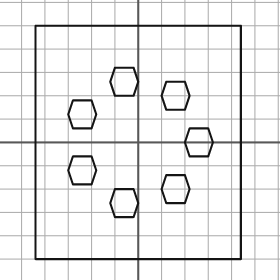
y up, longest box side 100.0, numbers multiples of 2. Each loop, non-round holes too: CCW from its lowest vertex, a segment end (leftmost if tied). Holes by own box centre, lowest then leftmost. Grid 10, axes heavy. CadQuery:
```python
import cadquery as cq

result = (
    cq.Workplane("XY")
    .moveTo(-44.0, -50.0)
    .lineTo(44.0, -50.0)
    .lineTo(44.0, 50.0)
    .lineTo(-44.0, 50.0)
    .close()
    .moveTo(-10.0, -32.0)
    .lineTo(-2.0, -32.0)
    .lineTo(0.0, -26.0)
    .lineTo(-2.0, -20.0)
    .lineTo(-10.0, -20.0)
    .lineTo(-12.0, -26.0)
    .close()
    .moveTo(12.0, -26.0)
    .lineTo(20.0, -26.0)
    .lineTo(22.0, -20.0)
    .lineTo(20.0, -14.0)
    .lineTo(12.0, -14.0)
    .lineTo(10.0, -20.0)
    .close()
    .moveTo(-28.0, -18.0)
    .lineTo(-20.0, -18.0)
    .lineTo(-18.0, -12.0)
    .lineTo(-20.0, -6.0)
    .lineTo(-28.0, -6.0)
    .lineTo(-30.0, -12.0)
    .close()
    .moveTo(22.0, -6.0)
    .lineTo(30.0, -6.0)
    .lineTo(32.0, 0.0)
    .lineTo(30.0, 6.0)
    .lineTo(22.0, 6.0)
    .lineTo(20.0, 0.0)
    .close()
    .moveTo(-28.0, 6.0)
    .lineTo(-20.0, 6.0)
    .lineTo(-18.0, 12.0)
    .lineTo(-20.0, 18.0)
    .lineTo(-28.0, 18.0)
    .lineTo(-30.0, 12.0)
    .close()
    .moveTo(12.0, 14.0)
    .lineTo(20.0, 14.0)
    .lineTo(22.0, 20.0)
    .lineTo(20.0, 26.0)
    .lineTo(12.0, 26.0)
    .lineTo(10.0, 20.0)
    .close()
    .moveTo(-10.0, 20.0)
    .lineTo(-2.0, 20.0)
    .lineTo(0.0, 26.0)
    .lineTo(-2.0, 32.0)
    .lineTo(-10.0, 32.0)
    .lineTo(-12.0, 26.0)
    .close()
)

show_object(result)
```